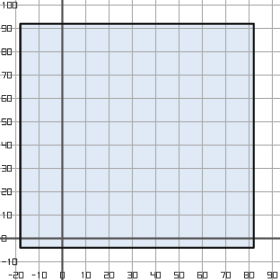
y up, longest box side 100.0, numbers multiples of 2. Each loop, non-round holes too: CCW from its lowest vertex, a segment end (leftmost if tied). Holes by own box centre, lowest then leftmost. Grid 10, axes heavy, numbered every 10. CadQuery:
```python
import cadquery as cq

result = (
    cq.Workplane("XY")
    .moveTo(-18.0, -4.0)
    .lineTo(82.0, -4.0)
    .lineTo(82.0, 92.0)
    .lineTo(-18.0, 92.0)
    .close()
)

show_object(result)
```